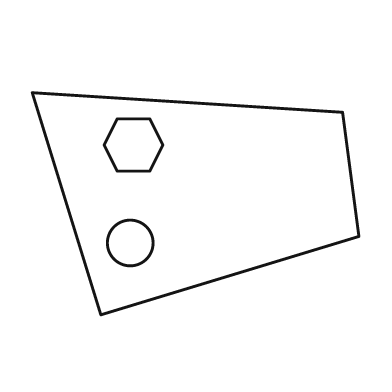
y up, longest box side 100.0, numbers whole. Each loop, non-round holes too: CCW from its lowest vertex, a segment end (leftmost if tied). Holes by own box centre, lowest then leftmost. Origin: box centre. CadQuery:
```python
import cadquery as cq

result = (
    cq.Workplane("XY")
    .moveTo(-29.0, -34.0)
    .lineTo(50.0, -10.0)
    .lineTo(45.0, 28.0)
    .lineTo(-50.0, 34.0)
    .close()
    .moveTo(-20.0, -12.0)
    .circle(7.0)
    .moveTo(-24.0, 10.0)
    .lineTo(-14.0, 10.0)
    .lineTo(-10.0, 18.0)
    .lineTo(-14.0, 26.0)
    .lineTo(-24.0, 26.0)
    .lineTo(-28.0, 18.0)
    .close()
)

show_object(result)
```